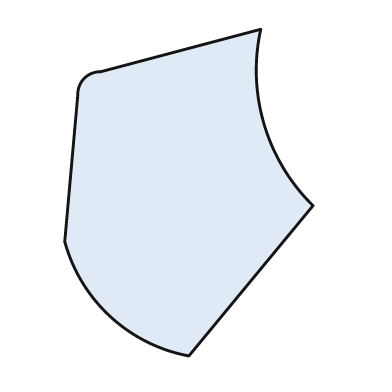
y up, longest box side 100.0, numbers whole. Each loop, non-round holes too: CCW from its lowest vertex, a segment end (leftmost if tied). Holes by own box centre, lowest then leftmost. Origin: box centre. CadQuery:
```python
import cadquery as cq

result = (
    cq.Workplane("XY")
    .moveTo(0.0, -50.0)
    .lineTo(38.0, -4.0)
    .threePointArc((23.0, 21.0), (22.0, 50.0))
    .lineTo(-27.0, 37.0)
    .threePointArc((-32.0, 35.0), (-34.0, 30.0))
    .lineTo(-38.0, -15.0)
    .threePointArc((-24.0, -38.0), (0.0, -50.0))
    .close()
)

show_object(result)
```